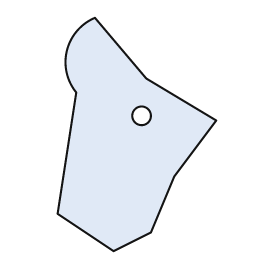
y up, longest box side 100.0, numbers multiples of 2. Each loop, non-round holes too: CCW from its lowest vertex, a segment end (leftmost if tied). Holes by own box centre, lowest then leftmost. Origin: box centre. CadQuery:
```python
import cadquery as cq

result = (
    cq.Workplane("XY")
    .moveTo(-10.0, -50.0)
    .lineTo(6.0, -42.0)
    .lineTo(16.0, -18.0)
    .lineTo(34.0, 6.0)
    .lineTo(4.0, 24.0)
    .lineTo(-18.0, 50.0)
    .threePointArc((-30.0, 36.0), (-26.0, 18.0))
    .lineTo(-34.0, -34.0)
    .close()
    .moveTo(2.0, 8.0)
    .circle(4.0)
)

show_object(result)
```